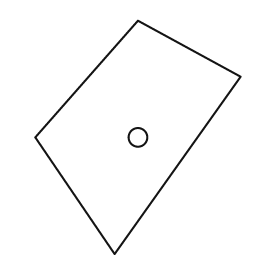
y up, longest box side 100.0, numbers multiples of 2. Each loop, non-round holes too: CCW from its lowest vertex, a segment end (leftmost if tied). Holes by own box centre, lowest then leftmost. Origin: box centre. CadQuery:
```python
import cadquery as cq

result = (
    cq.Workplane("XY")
    .moveTo(-10.0, -50.0)
    .lineTo(44.0, 26.0)
    .lineTo(0.0, 50.0)
    .lineTo(-44.0, 0.0)
    .close()
    .moveTo(0.0, 0.0)
    .circle(4.0)
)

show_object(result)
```